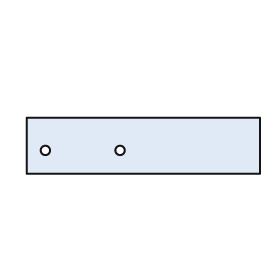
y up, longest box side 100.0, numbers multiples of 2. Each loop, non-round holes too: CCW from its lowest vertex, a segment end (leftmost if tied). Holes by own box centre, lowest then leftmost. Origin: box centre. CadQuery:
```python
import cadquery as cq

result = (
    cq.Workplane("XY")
    .moveTo(-50.0, -12.0)
    .lineTo(50.0, -12.0)
    .lineTo(50.0, 12.0)
    .lineTo(-50.0, 12.0)
    .close()
    .moveTo(-42.0, -2.0)
    .circle(2.0)
    .moveTo(-10.0, -2.0)
    .circle(2.0)
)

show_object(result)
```